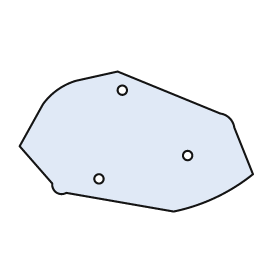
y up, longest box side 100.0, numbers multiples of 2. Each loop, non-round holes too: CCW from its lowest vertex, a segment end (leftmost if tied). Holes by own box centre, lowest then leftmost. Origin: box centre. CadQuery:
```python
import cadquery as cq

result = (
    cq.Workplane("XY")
    .moveTo(16.0, -30.0)
    .threePointArc((34.0, -24.0), (50.0, -14.0))
    .lineTo(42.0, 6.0)
    .threePointArc((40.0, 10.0), (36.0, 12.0))
    .lineTo(-8.0, 30.0)
    .lineTo(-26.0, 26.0)
    .threePointArc((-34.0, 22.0), (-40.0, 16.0))
    .lineTo(-50.0, -2.0)
    .lineTo(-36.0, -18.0)
    .threePointArc((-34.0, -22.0), (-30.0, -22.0))
    .close()
    .moveTo(-16.0, -16.0)
    .circle(2.0)
    .moveTo(22.0, -6.0)
    .circle(2.0)
    .moveTo(-6.0, 22.0)
    .circle(2.0)
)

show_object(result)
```